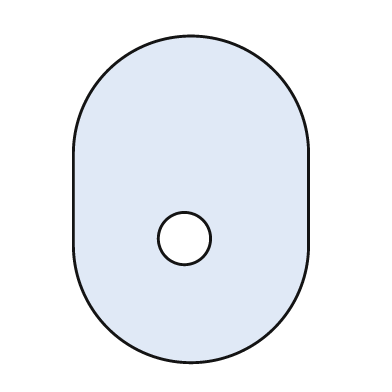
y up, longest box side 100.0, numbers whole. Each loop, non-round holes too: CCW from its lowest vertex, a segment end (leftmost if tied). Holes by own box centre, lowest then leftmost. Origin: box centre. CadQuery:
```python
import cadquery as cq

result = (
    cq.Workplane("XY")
    .moveTo(-36.0, -14.0)
    .threePointArc((0.0, -50.0), (36.0, -14.0))
    .lineTo(36.0, 14.0)
    .threePointArc((0.0, 50.0), (-36.0, 14.0))
    .close()
    .moveTo(-2.0, -12.0)
    .circle(8.0)
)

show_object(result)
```